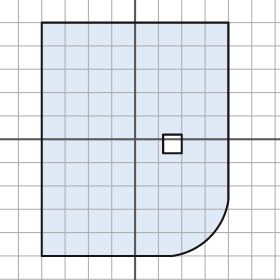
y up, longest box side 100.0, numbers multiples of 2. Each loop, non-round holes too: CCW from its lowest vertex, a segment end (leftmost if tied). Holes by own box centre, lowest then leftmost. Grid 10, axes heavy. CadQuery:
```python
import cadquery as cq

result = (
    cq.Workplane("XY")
    .moveTo(-40.0, -50.0)
    .lineTo(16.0, -50.0)
    .threePointArc((32.0, -42.0), (40.0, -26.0))
    .lineTo(40.0, 50.0)
    .lineTo(-40.0, 50.0)
    .close()
    .moveTo(12.0, -6.0)
    .lineTo(20.0, -6.0)
    .lineTo(20.0, 2.0)
    .lineTo(12.0, 2.0)
    .close()
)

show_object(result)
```